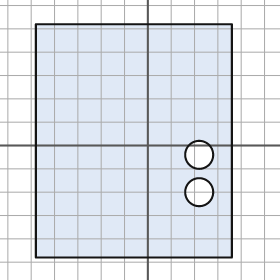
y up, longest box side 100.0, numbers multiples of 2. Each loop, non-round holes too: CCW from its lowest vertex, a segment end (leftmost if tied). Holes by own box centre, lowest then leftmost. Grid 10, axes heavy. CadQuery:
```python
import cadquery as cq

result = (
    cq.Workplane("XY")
    .moveTo(-48.0, -48.0)
    .lineTo(36.0, -48.0)
    .lineTo(36.0, 52.0)
    .lineTo(-48.0, 52.0)
    .close()
    .moveTo(22.0, -20.0)
    .circle(6.0)
    .moveTo(22.0, -4.0)
    .circle(6.0)
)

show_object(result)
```